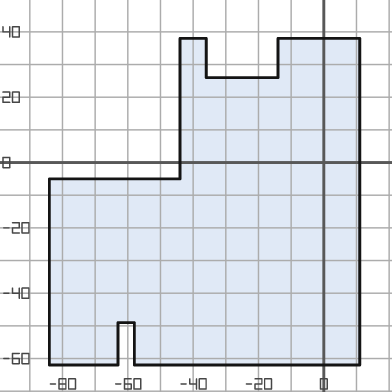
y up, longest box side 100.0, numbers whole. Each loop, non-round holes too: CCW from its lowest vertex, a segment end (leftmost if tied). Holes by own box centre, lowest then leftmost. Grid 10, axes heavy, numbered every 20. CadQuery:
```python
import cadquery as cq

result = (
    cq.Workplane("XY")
    .moveTo(-84.0, -62.0)
    .lineTo(-63.0, -62.0)
    .lineTo(-63.0, -49.0)
    .lineTo(-58.0, -49.0)
    .lineTo(-58.0, -62.0)
    .lineTo(11.0, -62.0)
    .lineTo(11.0, 38.0)
    .lineTo(-14.0, 38.0)
    .lineTo(-14.0, 26.0)
    .lineTo(-36.0, 26.0)
    .lineTo(-36.0, 38.0)
    .lineTo(-44.0, 38.0)
    .lineTo(-44.0, -5.0)
    .lineTo(-84.0, -5.0)
    .close()
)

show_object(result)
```